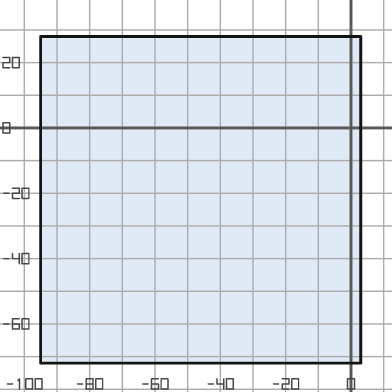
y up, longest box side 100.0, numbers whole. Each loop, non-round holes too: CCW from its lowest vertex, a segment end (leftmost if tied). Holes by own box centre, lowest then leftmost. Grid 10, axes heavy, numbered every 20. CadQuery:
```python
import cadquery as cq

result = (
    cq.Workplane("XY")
    .moveTo(-95.0, -72.0)
    .lineTo(3.0, -72.0)
    .lineTo(3.0, 28.0)
    .lineTo(-95.0, 28.0)
    .close()
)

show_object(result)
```